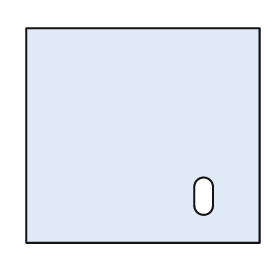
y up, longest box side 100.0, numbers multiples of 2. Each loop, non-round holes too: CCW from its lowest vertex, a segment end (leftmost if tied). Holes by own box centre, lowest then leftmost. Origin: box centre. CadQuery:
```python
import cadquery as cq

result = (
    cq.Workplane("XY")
    .moveTo(-50.0, -46.0)
    .lineTo(50.0, -46.0)
    .lineTo(50.0, 46.0)
    .lineTo(-50.0, 46.0)
    .close()
    .moveTo(22.0, -30.0)
    .threePointArc((26.0, -34.0), (30.0, -30.0))
    .lineTo(30.0, -22.0)
    .threePointArc((26.0, -18.0), (22.0, -22.0))
    .close()
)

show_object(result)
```